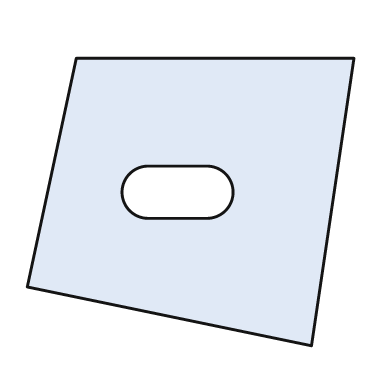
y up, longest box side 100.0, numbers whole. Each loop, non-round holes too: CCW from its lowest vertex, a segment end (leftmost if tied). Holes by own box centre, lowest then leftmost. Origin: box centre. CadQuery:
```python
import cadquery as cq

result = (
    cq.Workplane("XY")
    .moveTo(37.0, -44.0)
    .lineTo(50.0, 44.0)
    .lineTo(-35.0, 44.0)
    .lineTo(-50.0, -26.0)
    .close()
    .moveTo(-13.0, -5.0)
    .lineTo(5.0, -5.0)
    .threePointArc((13.0, 3.0), (5.0, 11.0))
    .lineTo(-13.0, 11.0)
    .threePointArc((-21.0, 3.0), (-13.0, -5.0))
    .close()
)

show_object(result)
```